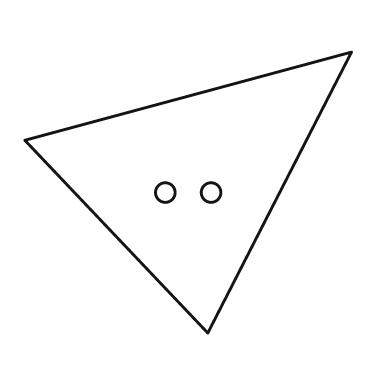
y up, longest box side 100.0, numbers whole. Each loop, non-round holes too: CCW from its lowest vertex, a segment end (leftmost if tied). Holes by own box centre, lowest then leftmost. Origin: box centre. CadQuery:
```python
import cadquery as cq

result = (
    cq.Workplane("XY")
    .moveTo(6.0, -43.0)
    .lineTo(50.0, 43.0)
    .lineTo(-50.0, 16.0)
    .close()
    .moveTo(-7.0, 0.0)
    .circle(3.0)
    .moveTo(7.0, 0.0)
    .circle(3.0)
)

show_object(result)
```